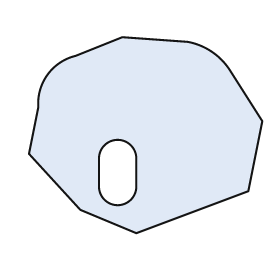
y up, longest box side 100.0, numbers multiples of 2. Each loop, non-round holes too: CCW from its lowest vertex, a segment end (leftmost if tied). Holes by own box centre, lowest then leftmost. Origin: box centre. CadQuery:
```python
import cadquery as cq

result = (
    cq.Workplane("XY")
    .moveTo(-4.0, -42.0)
    .lineTo(44.0, -24.0)
    .lineTo(50.0, 6.0)
    .lineTo(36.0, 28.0)
    .threePointArc((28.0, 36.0), (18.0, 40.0))
    .lineTo(-10.0, 42.0)
    .lineTo(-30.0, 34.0)
    .threePointArc((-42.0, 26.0), (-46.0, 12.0))
    .lineTo(-50.0, -8.0)
    .lineTo(-28.0, -32.0)
    .close()
    .moveTo(-20.0, -22.0)
    .threePointArc((-12.0, -30.0), (-4.0, -22.0))
    .lineTo(-4.0, -10.0)
    .threePointArc((-12.0, -2.0), (-20.0, -10.0))
    .close()
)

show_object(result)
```